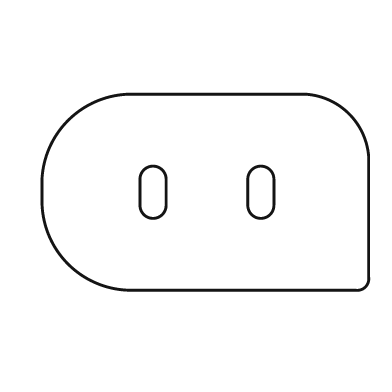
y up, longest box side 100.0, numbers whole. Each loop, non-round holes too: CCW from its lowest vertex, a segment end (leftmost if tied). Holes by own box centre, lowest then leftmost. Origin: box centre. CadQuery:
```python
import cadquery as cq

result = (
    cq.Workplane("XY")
    .moveTo(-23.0, -30.0)
    .lineTo(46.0, -30.0)
    .threePointArc((49.0, -29.0), (50.0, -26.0))
    .lineTo(50.0, 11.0)
    .threePointArc((44.0, 24.0), (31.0, 30.0))
    .lineTo(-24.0, 30.0)
    .threePointArc((-42.0, 22.0), (-50.0, 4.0))
    .lineTo(-50.0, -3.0)
    .threePointArc((-42.0, -22.0), (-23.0, -30.0))
    .close()
    .moveTo(-20.0, -4.0)
    .threePointArc((-16.0, -8.0), (-12.0, -4.0))
    .lineTo(-12.0, 4.0)
    .threePointArc((-16.0, 8.0), (-20.0, 4.0))
    .close()
    .moveTo(13.0, -4.0)
    .threePointArc((17.0, -8.0), (21.0, -4.0))
    .lineTo(21.0, 4.0)
    .threePointArc((17.0, 8.0), (13.0, 4.0))
    .close()
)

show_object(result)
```